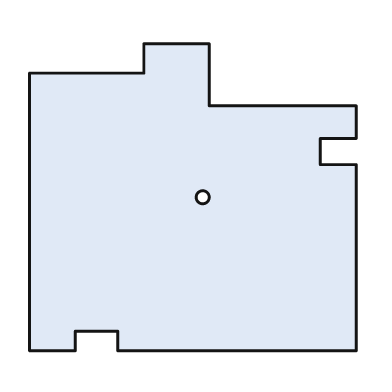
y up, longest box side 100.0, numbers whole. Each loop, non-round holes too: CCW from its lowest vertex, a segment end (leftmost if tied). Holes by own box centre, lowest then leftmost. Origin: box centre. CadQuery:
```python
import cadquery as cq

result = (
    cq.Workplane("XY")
    .moveTo(-50.0, -47.0)
    .lineTo(-36.0, -47.0)
    .lineTo(-36.0, -41.0)
    .lineTo(-23.0, -41.0)
    .lineTo(-23.0, -47.0)
    .lineTo(50.0, -47.0)
    .lineTo(50.0, 10.0)
    .lineTo(39.0, 10.0)
    .lineTo(39.0, 18.0)
    .lineTo(50.0, 18.0)
    .lineTo(50.0, 28.0)
    .lineTo(5.0, 28.0)
    .lineTo(5.0, 47.0)
    .lineTo(-15.0, 47.0)
    .lineTo(-15.0, 38.0)
    .lineTo(-50.0, 38.0)
    .close()
    .moveTo(3.0, 0.0)
    .circle(2.0)
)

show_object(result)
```